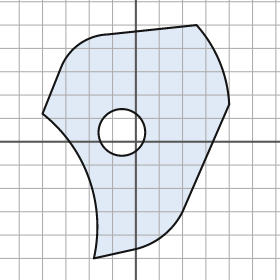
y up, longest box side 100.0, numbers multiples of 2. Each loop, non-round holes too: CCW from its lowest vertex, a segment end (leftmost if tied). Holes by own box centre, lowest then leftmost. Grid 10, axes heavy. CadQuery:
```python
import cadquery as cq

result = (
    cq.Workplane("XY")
    .moveTo(-18.0, -50.0)
    .lineTo(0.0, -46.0)
    .threePointArc((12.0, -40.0), (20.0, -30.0))
    .lineTo(40.0, 16.0)
    .threePointArc((36.0, 34.0), (26.0, 50.0))
    .lineTo(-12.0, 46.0)
    .threePointArc((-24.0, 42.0), (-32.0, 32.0))
    .lineTo(-40.0, 12.0)
    .threePointArc((-20.0, -16.0), (-18.0, -50.0))
    .close()
    .moveTo(-6.0, 4.0)
    .circle(10.0)
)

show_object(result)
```